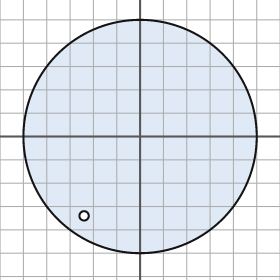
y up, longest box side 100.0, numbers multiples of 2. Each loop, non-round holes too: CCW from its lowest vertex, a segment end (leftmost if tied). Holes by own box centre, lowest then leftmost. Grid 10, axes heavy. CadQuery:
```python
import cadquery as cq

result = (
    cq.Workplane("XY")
    .moveTo(0.0, 0.0)
    .circle(50.0)
    .moveTo(-24.0, -34.0)
    .circle(2.0)
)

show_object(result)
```